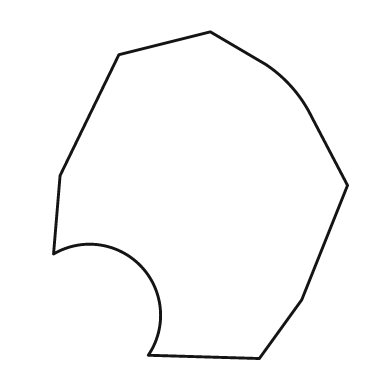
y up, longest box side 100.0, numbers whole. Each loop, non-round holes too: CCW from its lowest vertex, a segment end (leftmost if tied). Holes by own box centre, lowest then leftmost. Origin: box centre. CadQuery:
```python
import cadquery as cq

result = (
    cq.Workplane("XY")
    .moveTo(18.0, -50.0)
    .lineTo(31.0, -32.0)
    .lineTo(45.0, 3.0)
    .lineTo(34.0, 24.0)
    .threePointArc((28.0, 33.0), (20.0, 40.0))
    .lineTo(3.0, 50.0)
    .lineTo(-25.0, 43.0)
    .lineTo(-43.0, 6.0)
    .lineTo(-45.0, -18.0)
    .threePointArc((-18.0, -22.0), (-16.0, -49.0))
    .close()
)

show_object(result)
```